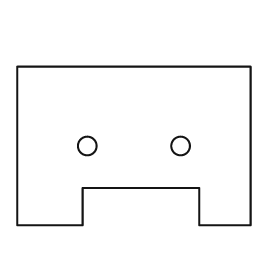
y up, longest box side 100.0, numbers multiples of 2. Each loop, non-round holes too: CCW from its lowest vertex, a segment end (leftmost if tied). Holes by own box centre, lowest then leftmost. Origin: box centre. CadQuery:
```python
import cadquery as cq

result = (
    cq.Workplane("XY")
    .moveTo(-50.0, -34.0)
    .lineTo(-22.0, -34.0)
    .lineTo(-22.0, -18.0)
    .lineTo(28.0, -18.0)
    .lineTo(28.0, -34.0)
    .lineTo(50.0, -34.0)
    .lineTo(50.0, 34.0)
    .lineTo(-50.0, 34.0)
    .close()
    .moveTo(-20.0, 0.0)
    .circle(4.0)
    .moveTo(20.0, 0.0)
    .circle(4.0)
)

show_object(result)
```